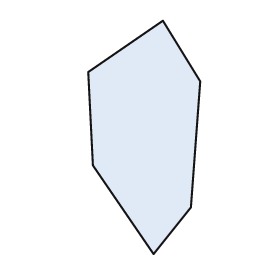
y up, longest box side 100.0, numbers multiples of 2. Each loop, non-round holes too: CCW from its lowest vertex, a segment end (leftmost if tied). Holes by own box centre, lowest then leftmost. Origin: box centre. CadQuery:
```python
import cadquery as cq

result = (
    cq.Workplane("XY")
    .moveTo(4.0, -50.0)
    .lineTo(20.0, -30.0)
    .lineTo(24.0, 24.0)
    .lineTo(8.0, 50.0)
    .lineTo(-24.0, 28.0)
    .lineTo(-22.0, -12.0)
    .close()
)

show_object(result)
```